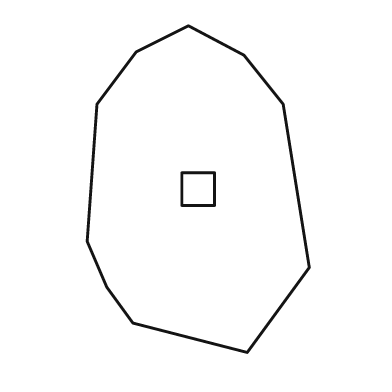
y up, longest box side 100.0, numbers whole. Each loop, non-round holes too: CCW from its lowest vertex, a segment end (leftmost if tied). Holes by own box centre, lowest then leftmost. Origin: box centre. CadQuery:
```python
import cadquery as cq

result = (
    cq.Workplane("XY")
    .moveTo(15.0, -50.0)
    .lineTo(34.0, -24.0)
    .lineTo(26.0, 26.0)
    .lineTo(14.0, 41.0)
    .lineTo(-3.0, 50.0)
    .lineTo(-19.0, 42.0)
    .lineTo(-31.0, 26.0)
    .lineTo(-34.0, -16.0)
    .lineTo(-28.0, -30.0)
    .lineTo(-20.0, -41.0)
    .close()
    .moveTo(-5.0, -5.0)
    .lineTo(5.0, -5.0)
    .lineTo(5.0, 5.0)
    .lineTo(-5.0, 5.0)
    .close()
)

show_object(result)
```